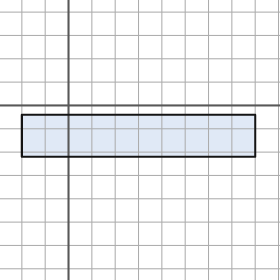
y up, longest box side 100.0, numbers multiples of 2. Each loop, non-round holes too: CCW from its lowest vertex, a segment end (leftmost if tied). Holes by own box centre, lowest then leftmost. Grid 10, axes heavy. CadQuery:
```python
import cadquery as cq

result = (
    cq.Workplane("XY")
    .moveTo(-20.0, -22.0)
    .lineTo(80.0, -22.0)
    .lineTo(80.0, -4.0)
    .lineTo(-20.0, -4.0)
    .close()
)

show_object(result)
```